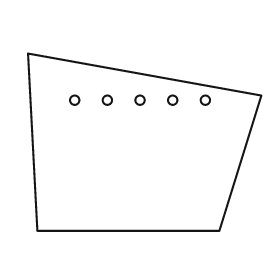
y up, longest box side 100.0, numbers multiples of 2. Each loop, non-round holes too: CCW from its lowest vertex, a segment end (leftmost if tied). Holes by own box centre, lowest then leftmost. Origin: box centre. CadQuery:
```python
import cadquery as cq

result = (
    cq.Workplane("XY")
    .moveTo(-46.0, -38.0)
    .lineTo(32.0, -38.0)
    .lineTo(50.0, 20.0)
    .lineTo(-50.0, 38.0)
    .close()
    .moveTo(-30.0, 18.0)
    .circle(2.0)
    .moveTo(-16.0, 18.0)
    .circle(2.0)
    .moveTo(-2.0, 18.0)
    .circle(2.0)
    .moveTo(12.0, 18.0)
    .circle(2.0)
    .moveTo(26.0, 18.0)
    .circle(2.0)
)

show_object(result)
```